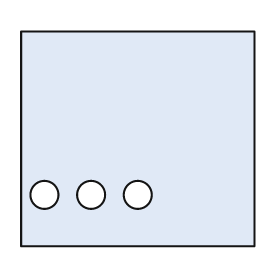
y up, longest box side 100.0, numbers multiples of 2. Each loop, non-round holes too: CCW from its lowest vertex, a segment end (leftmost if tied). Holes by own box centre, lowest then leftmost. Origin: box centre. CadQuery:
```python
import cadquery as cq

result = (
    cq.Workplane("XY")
    .moveTo(-50.0, -46.0)
    .lineTo(50.0, -46.0)
    .lineTo(50.0, 46.0)
    .lineTo(-50.0, 46.0)
    .close()
    .moveTo(-40.0, -24.0)
    .circle(6.0)
    .moveTo(-20.0, -24.0)
    .circle(6.0)
    .moveTo(0.0, -24.0)
    .circle(6.0)
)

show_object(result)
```